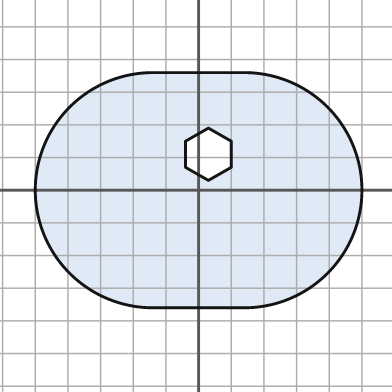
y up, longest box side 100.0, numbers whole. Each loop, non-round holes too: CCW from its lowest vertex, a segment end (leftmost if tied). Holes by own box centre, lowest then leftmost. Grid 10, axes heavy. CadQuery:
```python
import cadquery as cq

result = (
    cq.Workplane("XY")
    .moveTo(-14.0, -36.0)
    .lineTo(14.0, -36.0)
    .threePointArc((50.0, 0.0), (14.0, 36.0))
    .lineTo(-14.0, 36.0)
    .threePointArc((-50.0, 0.0), (-14.0, -36.0))
    .close()
    .moveTo(3.0, 3.0)
    .lineTo(10.0, 7.0)
    .lineTo(10.0, 15.0)
    .lineTo(3.0, 19.0)
    .lineTo(-4.0, 15.0)
    .lineTo(-4.0, 7.0)
    .close()
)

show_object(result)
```